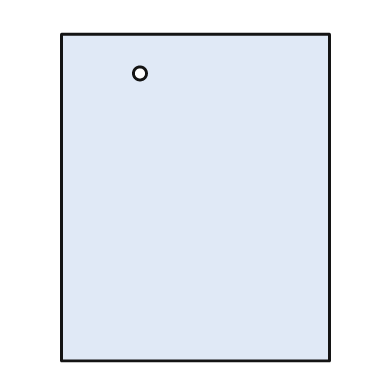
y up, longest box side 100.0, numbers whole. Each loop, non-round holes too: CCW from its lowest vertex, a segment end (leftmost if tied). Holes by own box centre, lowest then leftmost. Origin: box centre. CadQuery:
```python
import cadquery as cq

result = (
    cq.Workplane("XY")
    .moveTo(-41.0, -50.0)
    .lineTo(41.0, -50.0)
    .lineTo(41.0, 50.0)
    .lineTo(-41.0, 50.0)
    .close()
    .moveTo(-17.0, 38.0)
    .circle(2.0)
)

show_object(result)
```